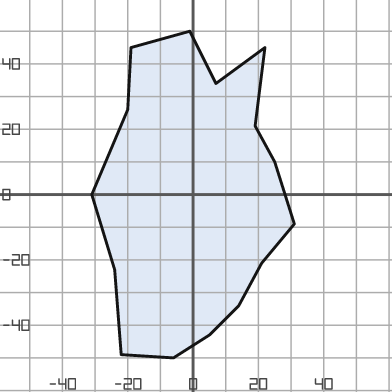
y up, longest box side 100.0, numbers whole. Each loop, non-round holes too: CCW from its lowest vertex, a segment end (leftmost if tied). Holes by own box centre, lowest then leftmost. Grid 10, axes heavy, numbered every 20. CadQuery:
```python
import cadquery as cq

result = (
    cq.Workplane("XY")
    .moveTo(-6.0, -50.0)
    .lineTo(5.0, -43.0)
    .lineTo(14.0, -34.0)
    .lineTo(21.0, -21.0)
    .lineTo(31.0, -9.0)
    .lineTo(25.0, 10.0)
    .lineTo(19.0, 21.0)
    .lineTo(22.0, 45.0)
    .lineTo(7.0, 34.0)
    .lineTo(-1.0, 50.0)
    .lineTo(-19.0, 45.0)
    .lineTo(-20.0, 26.0)
    .lineTo(-31.0, 0.0)
    .lineTo(-24.0, -23.0)
    .lineTo(-22.0, -49.0)
    .close()
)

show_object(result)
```